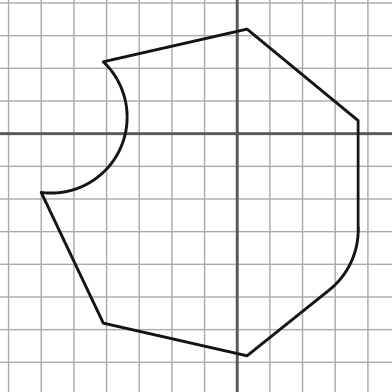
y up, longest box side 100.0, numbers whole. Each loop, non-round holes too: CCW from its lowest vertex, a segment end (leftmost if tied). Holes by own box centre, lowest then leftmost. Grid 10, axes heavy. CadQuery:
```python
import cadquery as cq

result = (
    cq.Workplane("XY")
    .moveTo(3.0, -68.0)
    .lineTo(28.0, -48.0)
    .threePointArc((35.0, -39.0), (37.0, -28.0))
    .lineTo(37.0, 4.0)
    .lineTo(3.0, 32.0)
    .lineTo(-41.0, 22.0)
    .threePointArc((-36.0, -5.0), (-60.0, -18.0))
    .lineTo(-41.0, -58.0)
    .close()
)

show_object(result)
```